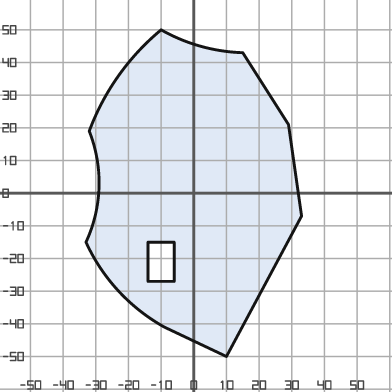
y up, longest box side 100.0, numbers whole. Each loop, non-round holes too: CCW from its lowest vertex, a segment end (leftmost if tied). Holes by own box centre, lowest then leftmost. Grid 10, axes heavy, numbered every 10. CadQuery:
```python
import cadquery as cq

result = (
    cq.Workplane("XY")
    .moveTo(10.0, -50.0)
    .lineTo(33.0, -7.0)
    .lineTo(29.0, 21.0)
    .lineTo(15.0, 43.0)
    .threePointArc((2.0, 45.0), (-10.0, 50.0))
    .threePointArc((-23.0, 36.0), (-32.0, 19.0))
    .threePointArc((-29.0, 2.0), (-33.0, -15.0))
    .threePointArc((-23.0, -30.0), (-9.0, -41.0))
    .close()
    .moveTo(-14.0, -27.0)
    .lineTo(-6.0, -27.0)
    .lineTo(-6.0, -15.0)
    .lineTo(-14.0, -15.0)
    .close()
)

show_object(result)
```